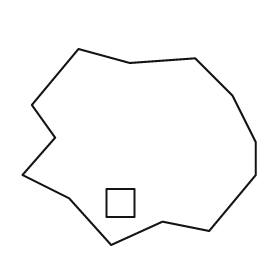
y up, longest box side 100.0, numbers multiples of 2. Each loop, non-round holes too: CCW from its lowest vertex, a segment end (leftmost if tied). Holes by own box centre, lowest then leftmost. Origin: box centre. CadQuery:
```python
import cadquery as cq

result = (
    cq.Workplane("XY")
    .moveTo(-12.0, -42.0)
    .lineTo(10.0, -32.0)
    .lineTo(30.0, -36.0)
    .lineTo(50.0, -12.0)
    .lineTo(50.0, 2.0)
    .lineTo(40.0, 22.0)
    .lineTo(24.0, 38.0)
    .lineTo(-4.0, 36.0)
    .lineTo(-26.0, 42.0)
    .lineTo(-46.0, 18.0)
    .lineTo(-36.0, 4.0)
    .lineTo(-50.0, -12.0)
    .lineTo(-30.0, -22.0)
    .close()
    .moveTo(-14.0, -30.0)
    .lineTo(-2.0, -30.0)
    .lineTo(-2.0, -18.0)
    .lineTo(-14.0, -18.0)
    .close()
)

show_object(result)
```